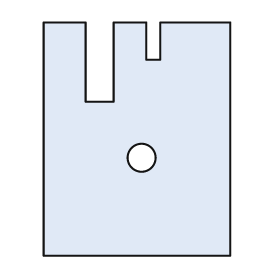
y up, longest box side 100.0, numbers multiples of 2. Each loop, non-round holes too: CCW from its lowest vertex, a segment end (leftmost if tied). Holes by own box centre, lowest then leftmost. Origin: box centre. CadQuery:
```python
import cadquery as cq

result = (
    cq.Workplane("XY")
    .moveTo(-40.0, -50.0)
    .lineTo(40.0, -50.0)
    .lineTo(40.0, 50.0)
    .lineTo(10.0, 50.0)
    .lineTo(10.0, 34.0)
    .lineTo(4.0, 34.0)
    .lineTo(4.0, 50.0)
    .lineTo(-10.0, 50.0)
    .lineTo(-10.0, 16.0)
    .lineTo(-22.0, 16.0)
    .lineTo(-22.0, 50.0)
    .lineTo(-40.0, 50.0)
    .close()
    .moveTo(2.0, -8.0)
    .circle(6.0)
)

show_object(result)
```